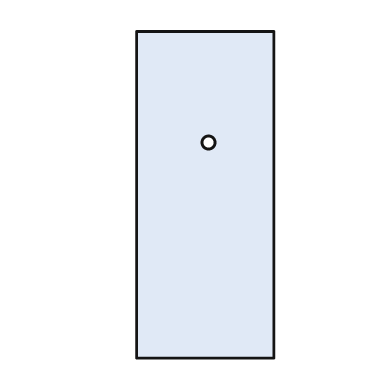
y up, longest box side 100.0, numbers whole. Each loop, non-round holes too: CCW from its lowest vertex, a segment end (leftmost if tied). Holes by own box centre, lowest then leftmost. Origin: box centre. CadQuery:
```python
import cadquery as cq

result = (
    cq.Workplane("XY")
    .moveTo(-21.0, -50.0)
    .lineTo(21.0, -50.0)
    .lineTo(21.0, 50.0)
    .lineTo(-21.0, 50.0)
    .close()
    .moveTo(1.0, 16.0)
    .circle(2.0)
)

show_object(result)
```